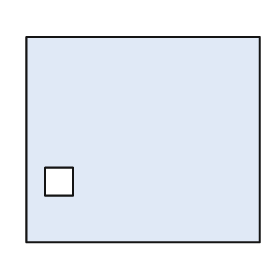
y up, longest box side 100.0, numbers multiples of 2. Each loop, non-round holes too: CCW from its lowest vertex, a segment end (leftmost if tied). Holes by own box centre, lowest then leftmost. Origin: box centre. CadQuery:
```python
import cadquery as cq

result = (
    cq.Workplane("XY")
    .moveTo(-50.0, -44.0)
    .lineTo(50.0, -44.0)
    .lineTo(50.0, 44.0)
    .lineTo(-50.0, 44.0)
    .close()
    .moveTo(-42.0, -24.0)
    .lineTo(-30.0, -24.0)
    .lineTo(-30.0, -12.0)
    .lineTo(-42.0, -12.0)
    .close()
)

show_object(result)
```